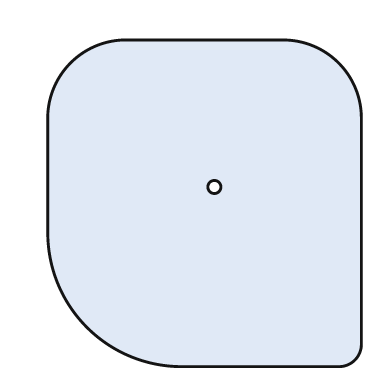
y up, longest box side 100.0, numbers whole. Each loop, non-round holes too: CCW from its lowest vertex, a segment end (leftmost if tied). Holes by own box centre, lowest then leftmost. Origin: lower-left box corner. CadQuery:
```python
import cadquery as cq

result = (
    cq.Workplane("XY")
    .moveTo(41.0, 0.0)
    .lineTo(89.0, 0.0)
    .threePointArc((94.0, 2.0), (96.0, 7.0))
    .lineTo(96.0, 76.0)
    .threePointArc((89.0, 93.0), (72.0, 100.0))
    .lineTo(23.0, 100.0)
    .threePointArc((7.0, 93.0), (0.0, 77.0))
    .lineTo(0.0, 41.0)
    .threePointArc((12.0, 12.0), (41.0, 0.0))
    .close()
    .moveTo(51.0, 55.0)
    .circle(2.0)
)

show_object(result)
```